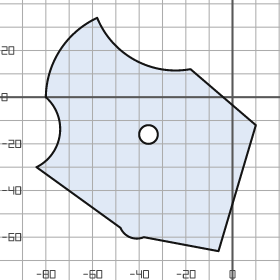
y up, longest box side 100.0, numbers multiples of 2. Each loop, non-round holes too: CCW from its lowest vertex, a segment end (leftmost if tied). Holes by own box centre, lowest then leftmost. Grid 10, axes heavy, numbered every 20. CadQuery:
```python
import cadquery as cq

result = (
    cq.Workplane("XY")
    .moveTo(-6.0, -66.0)
    .lineTo(10.0, -12.0)
    .lineTo(-18.0, 12.0)
    .threePointArc((-42.0, 16.0), (-58.0, 34.0))
    .threePointArc((-74.0, 20.0), (-80.0, 0.0))
    .threePointArc((-74.0, -16.0), (-84.0, -30.0))
    .lineTo(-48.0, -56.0)
    .threePointArc((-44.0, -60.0), (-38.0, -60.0))
    .close()
    .moveTo(-36.0, -16.0)
    .circle(4.0)
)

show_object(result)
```